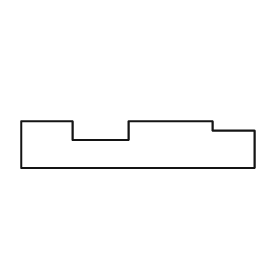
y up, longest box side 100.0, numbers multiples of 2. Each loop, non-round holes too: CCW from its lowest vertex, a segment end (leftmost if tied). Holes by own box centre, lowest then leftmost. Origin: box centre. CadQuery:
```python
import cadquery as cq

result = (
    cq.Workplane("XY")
    .moveTo(-50.0, -10.0)
    .lineTo(50.0, -10.0)
    .lineTo(50.0, 6.0)
    .lineTo(32.0, 6.0)
    .lineTo(32.0, 10.0)
    .lineTo(-4.0, 10.0)
    .lineTo(-4.0, 2.0)
    .lineTo(-28.0, 2.0)
    .lineTo(-28.0, 10.0)
    .lineTo(-50.0, 10.0)
    .close()
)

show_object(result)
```